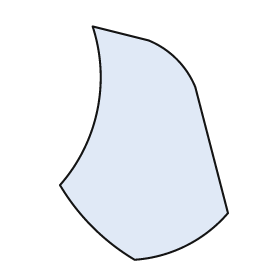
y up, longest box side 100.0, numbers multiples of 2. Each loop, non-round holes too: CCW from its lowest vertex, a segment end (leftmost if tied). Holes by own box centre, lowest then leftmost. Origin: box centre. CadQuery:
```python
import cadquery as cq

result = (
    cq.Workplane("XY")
    .moveTo(-4.0, -50.0)
    .threePointArc((18.0, -44.0), (36.0, -30.0))
    .lineTo(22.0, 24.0)
    .threePointArc((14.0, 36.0), (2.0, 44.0))
    .lineTo(-22.0, 50.0)
    .threePointArc((-20.0, 14.0), (-36.0, -18.0))
    .threePointArc((-22.0, -36.0), (-4.0, -50.0))
    .close()
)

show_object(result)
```